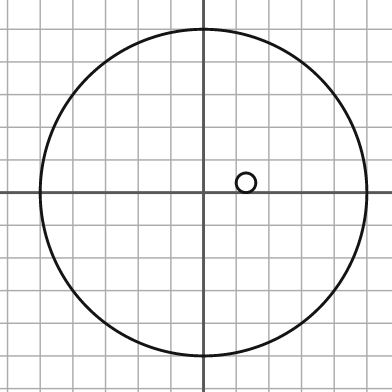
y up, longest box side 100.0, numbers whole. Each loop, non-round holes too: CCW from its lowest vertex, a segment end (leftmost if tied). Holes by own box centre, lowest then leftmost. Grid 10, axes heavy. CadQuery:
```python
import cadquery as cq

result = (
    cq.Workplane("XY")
    .moveTo(0.0, 0.0)
    .circle(50.0)
    .moveTo(13.0, 3.0)
    .circle(3.0)
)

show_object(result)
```